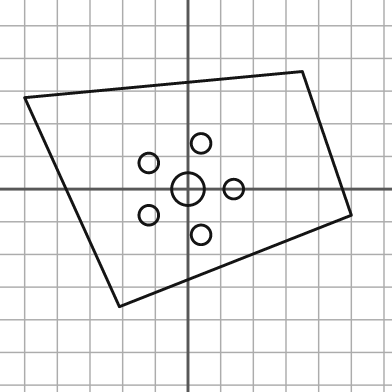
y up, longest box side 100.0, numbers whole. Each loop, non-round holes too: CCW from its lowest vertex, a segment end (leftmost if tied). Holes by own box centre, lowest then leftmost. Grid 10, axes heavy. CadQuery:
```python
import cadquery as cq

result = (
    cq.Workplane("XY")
    .moveTo(-21.0, -36.0)
    .lineTo(50.0, -8.0)
    .lineTo(35.0, 36.0)
    .lineTo(-50.0, 28.0)
    .close()
    .moveTo(4.0, -14.0)
    .circle(3.0)
    .moveTo(-12.0, -8.0)
    .circle(3.0)
    .moveTo(0.0, 0.0)
    .circle(5.0)
    .moveTo(14.0, 0.0)
    .circle(3.0)
    .moveTo(-12.0, 8.0)
    .circle(3.0)
    .moveTo(4.0, 14.0)
    .circle(3.0)
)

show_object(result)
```